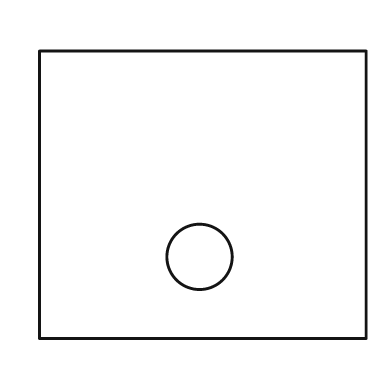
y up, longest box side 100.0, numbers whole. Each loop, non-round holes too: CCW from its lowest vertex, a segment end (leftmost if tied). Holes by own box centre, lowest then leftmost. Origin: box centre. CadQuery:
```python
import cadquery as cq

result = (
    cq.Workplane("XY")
    .moveTo(-50.0, -44.0)
    .lineTo(50.0, -44.0)
    .lineTo(50.0, 44.0)
    .lineTo(-50.0, 44.0)
    .close()
    .moveTo(-1.0, -19.0)
    .circle(10.0)
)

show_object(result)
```